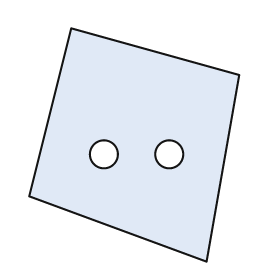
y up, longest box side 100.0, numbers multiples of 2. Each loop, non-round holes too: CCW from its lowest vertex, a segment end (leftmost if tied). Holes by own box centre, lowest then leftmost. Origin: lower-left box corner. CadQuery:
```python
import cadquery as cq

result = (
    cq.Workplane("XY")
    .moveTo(76.0, 0.0)
    .lineTo(90.0, 80.0)
    .lineTo(18.0, 100.0)
    .lineTo(0.0, 28.0)
    .close()
    .moveTo(32.0, 46.0)
    .circle(6.0)
    .moveTo(60.0, 46.0)
    .circle(6.0)
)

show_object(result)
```